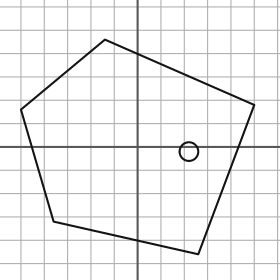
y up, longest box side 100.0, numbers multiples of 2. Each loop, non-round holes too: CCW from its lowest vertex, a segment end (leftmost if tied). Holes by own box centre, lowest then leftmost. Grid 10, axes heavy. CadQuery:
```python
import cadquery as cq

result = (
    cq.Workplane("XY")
    .moveTo(26.0, -46.0)
    .lineTo(50.0, 18.0)
    .lineTo(-14.0, 46.0)
    .lineTo(-50.0, 16.0)
    .lineTo(-36.0, -32.0)
    .close()
    .moveTo(22.0, -2.0)
    .circle(4.0)
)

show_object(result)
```